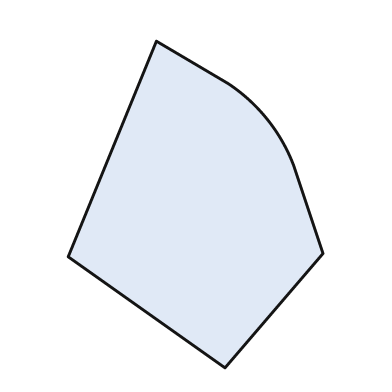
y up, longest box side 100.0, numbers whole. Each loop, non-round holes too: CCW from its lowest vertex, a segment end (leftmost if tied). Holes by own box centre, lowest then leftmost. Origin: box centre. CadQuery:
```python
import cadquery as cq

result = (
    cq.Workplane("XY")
    .moveTo(9.0, -50.0)
    .lineTo(39.0, -15.0)
    .lineTo(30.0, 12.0)
    .threePointArc((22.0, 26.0), (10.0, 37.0))
    .lineTo(-12.0, 50.0)
    .lineTo(-39.0, -16.0)
    .close()
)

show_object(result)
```